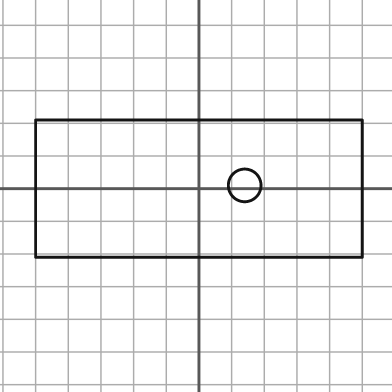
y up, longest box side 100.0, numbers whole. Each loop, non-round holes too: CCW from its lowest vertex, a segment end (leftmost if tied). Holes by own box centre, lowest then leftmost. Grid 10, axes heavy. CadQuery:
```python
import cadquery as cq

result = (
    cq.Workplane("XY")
    .moveTo(-50.0, -21.0)
    .lineTo(50.0, -21.0)
    .lineTo(50.0, 21.0)
    .lineTo(-50.0, 21.0)
    .close()
    .moveTo(14.0, 1.0)
    .circle(5.0)
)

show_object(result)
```